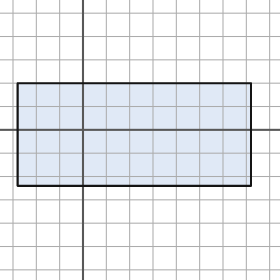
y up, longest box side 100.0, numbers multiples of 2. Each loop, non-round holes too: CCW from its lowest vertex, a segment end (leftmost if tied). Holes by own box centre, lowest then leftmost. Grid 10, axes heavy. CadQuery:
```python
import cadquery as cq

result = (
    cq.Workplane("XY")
    .moveTo(-28.0, -24.0)
    .lineTo(72.0, -24.0)
    .lineTo(72.0, 20.0)
    .lineTo(-28.0, 20.0)
    .close()
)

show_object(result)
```